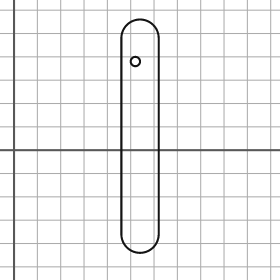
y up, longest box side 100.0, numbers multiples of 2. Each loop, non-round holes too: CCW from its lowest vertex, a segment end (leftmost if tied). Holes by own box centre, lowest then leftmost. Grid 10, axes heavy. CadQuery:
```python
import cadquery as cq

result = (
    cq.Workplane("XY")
    .moveTo(46.0, -36.0)
    .threePointArc((54.0, -44.0), (62.0, -36.0))
    .lineTo(62.0, 48.0)
    .threePointArc((54.0, 56.0), (46.0, 48.0))
    .close()
    .moveTo(52.0, 38.0)
    .circle(2.0)
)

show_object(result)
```